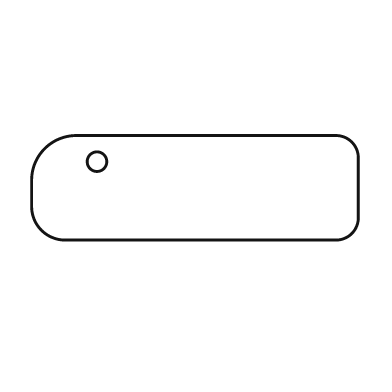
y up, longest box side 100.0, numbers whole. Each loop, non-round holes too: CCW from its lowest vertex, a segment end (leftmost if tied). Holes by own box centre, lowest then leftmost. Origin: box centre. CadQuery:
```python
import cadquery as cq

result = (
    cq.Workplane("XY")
    .moveTo(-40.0, -16.0)
    .lineTo(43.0, -16.0)
    .threePointArc((48.0, -14.0), (50.0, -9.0))
    .lineTo(50.0, 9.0)
    .threePointArc((48.0, 14.0), (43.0, 16.0))
    .lineTo(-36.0, 16.0)
    .threePointArc((-46.0, 12.0), (-50.0, 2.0))
    .lineTo(-50.0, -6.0)
    .threePointArc((-47.0, -13.0), (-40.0, -16.0))
    .close()
    .moveTo(-30.0, 8.0)
    .circle(3.0)
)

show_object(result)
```